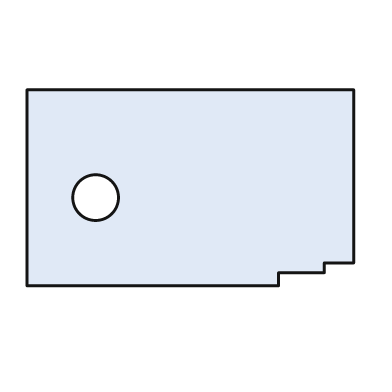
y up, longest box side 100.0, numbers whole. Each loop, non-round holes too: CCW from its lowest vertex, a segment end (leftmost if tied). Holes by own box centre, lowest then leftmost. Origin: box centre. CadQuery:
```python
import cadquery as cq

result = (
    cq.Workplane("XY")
    .moveTo(-50.0, -30.0)
    .lineTo(27.0, -30.0)
    .lineTo(27.0, -26.0)
    .lineTo(41.0, -26.0)
    .lineTo(41.0, -23.0)
    .lineTo(50.0, -23.0)
    .lineTo(50.0, 30.0)
    .lineTo(-50.0, 30.0)
    .close()
    .moveTo(-29.0, -3.0)
    .circle(7.0)
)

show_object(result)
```